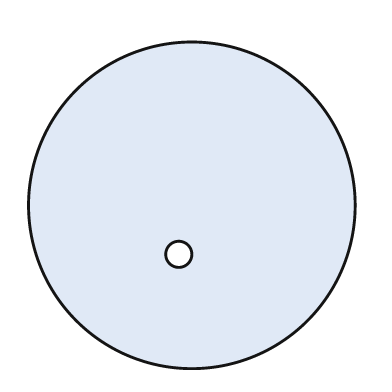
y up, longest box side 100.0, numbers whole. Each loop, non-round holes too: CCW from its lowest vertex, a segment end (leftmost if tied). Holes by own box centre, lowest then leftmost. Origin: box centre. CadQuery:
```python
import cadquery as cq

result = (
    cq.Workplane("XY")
    .moveTo(0.0, 0.0)
    .circle(50.0)
    .moveTo(-4.0, -15.0)
    .circle(4.0)
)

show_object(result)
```